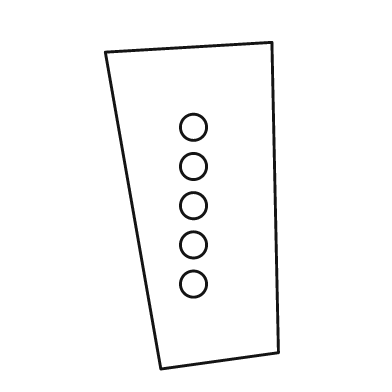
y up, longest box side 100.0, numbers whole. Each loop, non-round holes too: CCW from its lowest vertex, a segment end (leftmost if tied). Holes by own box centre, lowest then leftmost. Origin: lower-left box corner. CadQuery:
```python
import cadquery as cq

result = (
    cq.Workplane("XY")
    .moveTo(17.0, 0.0)
    .lineTo(53.0, 5.0)
    .lineTo(51.0, 100.0)
    .lineTo(0.0, 97.0)
    .close()
    .moveTo(27.0, 26.0)
    .circle(4.0)
    .moveTo(27.0, 38.0)
    .circle(4.0)
    .moveTo(27.0, 50.0)
    .circle(4.0)
    .moveTo(27.0, 62.0)
    .circle(4.0)
    .moveTo(27.0, 74.0)
    .circle(4.0)
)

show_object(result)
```